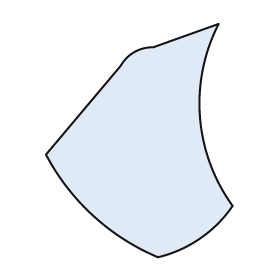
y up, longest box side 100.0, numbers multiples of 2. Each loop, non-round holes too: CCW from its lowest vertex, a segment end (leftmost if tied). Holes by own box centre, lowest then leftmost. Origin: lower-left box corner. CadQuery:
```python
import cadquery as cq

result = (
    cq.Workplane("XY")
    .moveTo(48.0, 0.0)
    .threePointArc((66.0, 8.0), (80.0, 22.0))
    .threePointArc((66.0, 60.0), (74.0, 100.0))
    .lineTo(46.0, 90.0)
    .threePointArc((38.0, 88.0), (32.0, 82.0))
    .lineTo(0.0, 44.0)
    .threePointArc((20.0, 18.0), (48.0, 0.0))
    .close()
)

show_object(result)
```